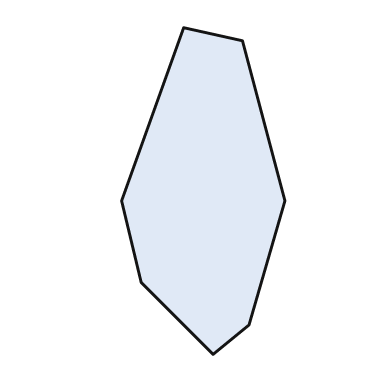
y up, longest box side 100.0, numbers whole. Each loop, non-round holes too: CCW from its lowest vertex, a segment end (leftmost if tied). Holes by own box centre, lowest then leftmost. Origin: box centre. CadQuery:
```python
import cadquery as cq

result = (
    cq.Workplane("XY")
    .moveTo(3.0, -50.0)
    .lineTo(14.0, -41.0)
    .lineTo(25.0, -3.0)
    .lineTo(12.0, 46.0)
    .lineTo(-6.0, 50.0)
    .lineTo(-25.0, -3.0)
    .lineTo(-19.0, -28.0)
    .close()
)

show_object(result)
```